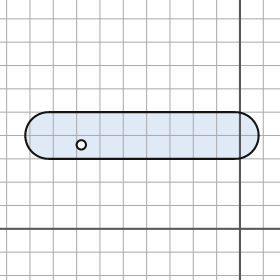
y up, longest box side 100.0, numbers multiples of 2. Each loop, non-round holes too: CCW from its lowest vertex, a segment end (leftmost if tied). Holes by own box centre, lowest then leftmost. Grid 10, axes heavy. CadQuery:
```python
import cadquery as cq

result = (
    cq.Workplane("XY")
    .moveTo(-82.0, 30.0)
    .lineTo(-2.0, 30.0)
    .threePointArc((8.0, 40.0), (-2.0, 50.0))
    .lineTo(-82.0, 50.0)
    .threePointArc((-92.0, 40.0), (-82.0, 30.0))
    .close()
    .moveTo(-68.0, 36.0)
    .circle(2.0)
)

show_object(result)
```